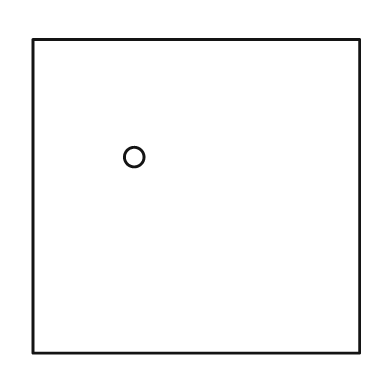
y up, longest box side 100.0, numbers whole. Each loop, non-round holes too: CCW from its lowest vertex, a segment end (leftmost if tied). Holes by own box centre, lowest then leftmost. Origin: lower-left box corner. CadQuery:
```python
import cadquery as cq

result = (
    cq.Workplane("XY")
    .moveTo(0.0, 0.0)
    .lineTo(100.0, 0.0)
    .lineTo(100.0, 96.0)
    .lineTo(0.0, 96.0)
    .close()
    .moveTo(31.0, 60.0)
    .circle(3.0)
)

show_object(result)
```